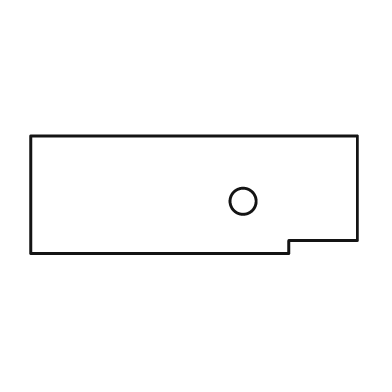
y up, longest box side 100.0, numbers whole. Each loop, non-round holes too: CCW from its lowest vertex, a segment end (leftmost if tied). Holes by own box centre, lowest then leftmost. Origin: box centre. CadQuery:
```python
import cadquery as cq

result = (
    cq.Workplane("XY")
    .moveTo(-50.0, -18.0)
    .lineTo(29.0, -18.0)
    .lineTo(29.0, -14.0)
    .lineTo(50.0, -14.0)
    .lineTo(50.0, 18.0)
    .lineTo(-50.0, 18.0)
    .close()
    .moveTo(15.0, -2.0)
    .circle(4.0)
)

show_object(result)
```